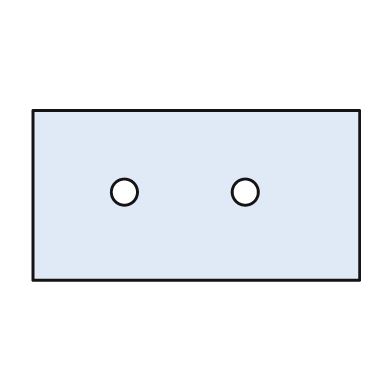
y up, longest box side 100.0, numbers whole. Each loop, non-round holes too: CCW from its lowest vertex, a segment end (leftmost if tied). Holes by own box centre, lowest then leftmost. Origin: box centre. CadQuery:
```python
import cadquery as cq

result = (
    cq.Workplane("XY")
    .moveTo(-50.0, -26.0)
    .lineTo(50.0, -26.0)
    .lineTo(50.0, 26.0)
    .lineTo(-50.0, 26.0)
    .close()
    .moveTo(-22.0, 1.0)
    .circle(4.0)
    .moveTo(15.0, 1.0)
    .circle(4.0)
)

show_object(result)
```